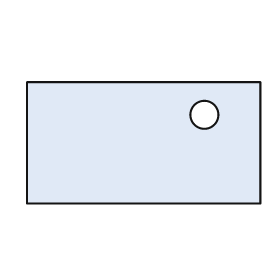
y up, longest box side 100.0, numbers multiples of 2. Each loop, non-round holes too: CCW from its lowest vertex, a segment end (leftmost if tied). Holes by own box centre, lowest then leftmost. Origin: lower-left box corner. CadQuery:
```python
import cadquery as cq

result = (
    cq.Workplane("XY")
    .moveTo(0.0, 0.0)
    .lineTo(100.0, 0.0)
    .lineTo(100.0, 52.0)
    .lineTo(0.0, 52.0)
    .close()
    .moveTo(76.0, 38.0)
    .circle(6.0)
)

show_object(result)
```